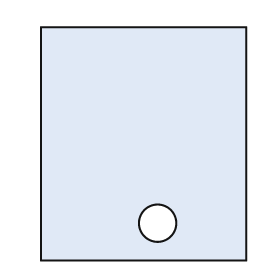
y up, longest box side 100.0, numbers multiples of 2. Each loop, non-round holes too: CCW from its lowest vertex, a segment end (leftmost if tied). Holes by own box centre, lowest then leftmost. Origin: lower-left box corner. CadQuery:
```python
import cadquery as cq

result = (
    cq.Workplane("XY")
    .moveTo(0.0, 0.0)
    .lineTo(88.0, 0.0)
    .lineTo(88.0, 100.0)
    .lineTo(0.0, 100.0)
    .close()
    .moveTo(50.0, 16.0)
    .circle(8.0)
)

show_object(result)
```